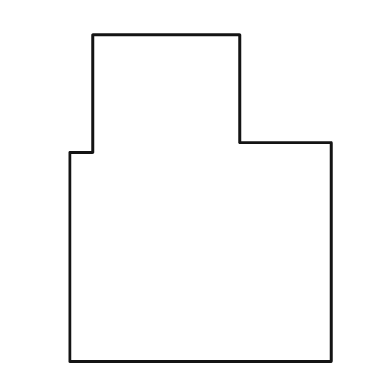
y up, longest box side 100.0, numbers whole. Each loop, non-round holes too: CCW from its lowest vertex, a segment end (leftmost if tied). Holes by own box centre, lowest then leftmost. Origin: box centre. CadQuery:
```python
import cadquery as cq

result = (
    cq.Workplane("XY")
    .moveTo(-40.0, -50.0)
    .lineTo(40.0, -50.0)
    .lineTo(40.0, 17.0)
    .lineTo(12.0, 17.0)
    .lineTo(12.0, 50.0)
    .lineTo(-33.0, 50.0)
    .lineTo(-33.0, 14.0)
    .lineTo(-40.0, 14.0)
    .close()
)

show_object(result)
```